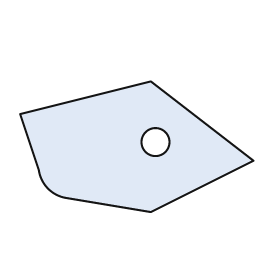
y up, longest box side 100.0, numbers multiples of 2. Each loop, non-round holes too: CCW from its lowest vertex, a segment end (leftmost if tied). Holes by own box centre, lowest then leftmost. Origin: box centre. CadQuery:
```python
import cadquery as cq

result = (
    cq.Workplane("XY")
    .moveTo(6.0, -28.0)
    .lineTo(50.0, -6.0)
    .lineTo(6.0, 28.0)
    .lineTo(-50.0, 14.0)
    .lineTo(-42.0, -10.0)
    .threePointArc((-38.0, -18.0), (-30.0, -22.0))
    .close()
    .moveTo(8.0, 2.0)
    .circle(6.0)
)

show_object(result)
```